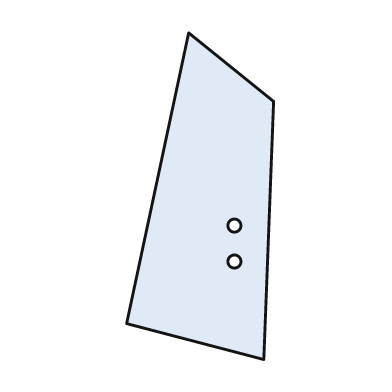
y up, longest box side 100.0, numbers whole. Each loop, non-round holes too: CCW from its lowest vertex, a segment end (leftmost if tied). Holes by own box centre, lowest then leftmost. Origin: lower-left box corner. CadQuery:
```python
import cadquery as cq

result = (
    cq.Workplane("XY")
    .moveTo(42.0, 0.0)
    .lineTo(45.0, 79.0)
    .lineTo(19.0, 100.0)
    .lineTo(0.0, 11.0)
    .close()
    .moveTo(33.0, 30.0)
    .circle(2.0)
    .moveTo(33.0, 41.0)
    .circle(2.0)
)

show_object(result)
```